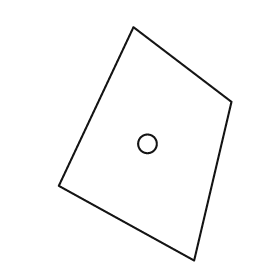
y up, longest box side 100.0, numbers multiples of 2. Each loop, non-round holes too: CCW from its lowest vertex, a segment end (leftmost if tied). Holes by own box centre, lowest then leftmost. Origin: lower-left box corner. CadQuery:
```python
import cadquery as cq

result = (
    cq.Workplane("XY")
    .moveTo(58.0, 0.0)
    .lineTo(74.0, 68.0)
    .lineTo(32.0, 100.0)
    .lineTo(0.0, 32.0)
    .close()
    .moveTo(38.0, 50.0)
    .circle(4.0)
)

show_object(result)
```